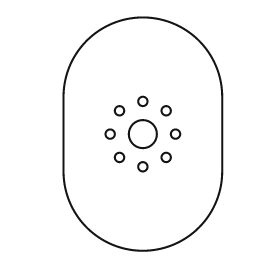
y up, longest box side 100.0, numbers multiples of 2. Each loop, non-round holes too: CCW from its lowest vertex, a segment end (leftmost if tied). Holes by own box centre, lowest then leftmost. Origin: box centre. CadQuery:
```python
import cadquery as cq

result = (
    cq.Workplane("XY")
    .moveTo(-34.0, -16.0)
    .threePointArc((0.0, -50.0), (34.0, -16.0))
    .lineTo(34.0, 16.0)
    .threePointArc((0.0, 50.0), (-34.0, 16.0))
    .close()
    .moveTo(0.0, -14.0)
    .circle(2.0)
    .moveTo(-10.0, -10.0)
    .circle(2.0)
    .moveTo(10.0, -10.0)
    .circle(2.0)
    .moveTo(-14.0, 0.0)
    .circle(2.0)
    .moveTo(0.0, 0.0)
    .circle(6.0)
    .moveTo(14.0, 0.0)
    .circle(2.0)
    .moveTo(-10.0, 10.0)
    .circle(2.0)
    .moveTo(10.0, 10.0)
    .circle(2.0)
    .moveTo(0.0, 14.0)
    .circle(2.0)
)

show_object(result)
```